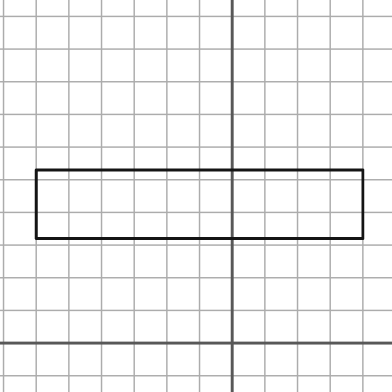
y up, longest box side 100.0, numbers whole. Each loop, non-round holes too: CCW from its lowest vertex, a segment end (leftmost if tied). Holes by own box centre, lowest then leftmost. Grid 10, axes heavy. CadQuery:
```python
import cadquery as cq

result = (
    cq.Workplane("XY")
    .moveTo(-60.0, 32.0)
    .lineTo(40.0, 32.0)
    .lineTo(40.0, 53.0)
    .lineTo(-60.0, 53.0)
    .close()
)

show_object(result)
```